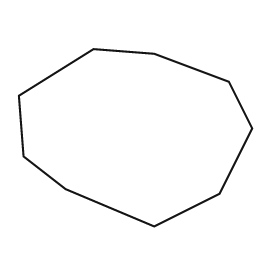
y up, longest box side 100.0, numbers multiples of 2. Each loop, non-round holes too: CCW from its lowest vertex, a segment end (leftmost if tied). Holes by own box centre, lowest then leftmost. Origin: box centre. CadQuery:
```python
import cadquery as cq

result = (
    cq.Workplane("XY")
    .moveTo(8.0, -38.0)
    .lineTo(36.0, -24.0)
    .lineTo(50.0, 4.0)
    .lineTo(40.0, 24.0)
    .lineTo(8.0, 36.0)
    .lineTo(-18.0, 38.0)
    .lineTo(-50.0, 18.0)
    .lineTo(-48.0, -8.0)
    .lineTo(-30.0, -22.0)
    .close()
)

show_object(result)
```